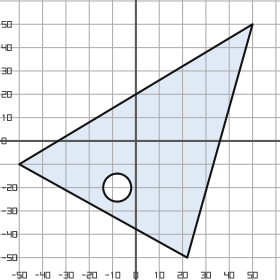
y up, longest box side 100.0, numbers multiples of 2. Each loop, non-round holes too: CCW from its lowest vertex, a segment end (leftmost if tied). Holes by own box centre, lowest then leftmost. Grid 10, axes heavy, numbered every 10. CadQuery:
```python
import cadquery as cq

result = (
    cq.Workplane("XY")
    .moveTo(22.0, -50.0)
    .lineTo(50.0, 50.0)
    .lineTo(-50.0, -10.0)
    .close()
    .moveTo(-8.0, -20.0)
    .circle(6.0)
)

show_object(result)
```